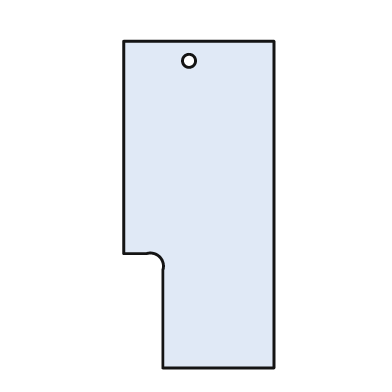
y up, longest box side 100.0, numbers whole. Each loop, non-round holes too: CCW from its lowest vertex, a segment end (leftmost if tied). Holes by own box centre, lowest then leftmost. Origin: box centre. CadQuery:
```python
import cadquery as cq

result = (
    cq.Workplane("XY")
    .moveTo(-11.0, -50.0)
    .lineTo(23.0, -50.0)
    .lineTo(23.0, 50.0)
    .lineTo(-23.0, 50.0)
    .lineTo(-23.0, -15.0)
    .lineTo(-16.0, -15.0)
    .threePointArc((-12.0, -16.0), (-11.0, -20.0))
    .close()
    .moveTo(-3.0, 44.0)
    .circle(2.0)
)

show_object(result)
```